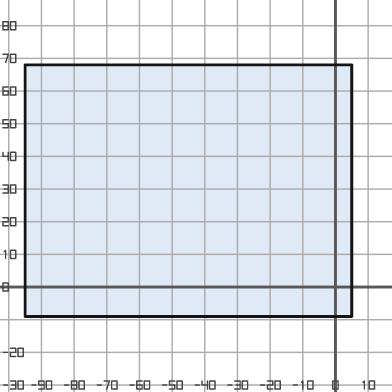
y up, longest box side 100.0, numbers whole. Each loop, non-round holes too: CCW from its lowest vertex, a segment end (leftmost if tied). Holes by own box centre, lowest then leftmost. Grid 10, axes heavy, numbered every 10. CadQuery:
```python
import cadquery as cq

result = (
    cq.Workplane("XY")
    .moveTo(-95.0, -9.0)
    .lineTo(5.0, -9.0)
    .lineTo(5.0, 68.0)
    .lineTo(-95.0, 68.0)
    .close()
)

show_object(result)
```